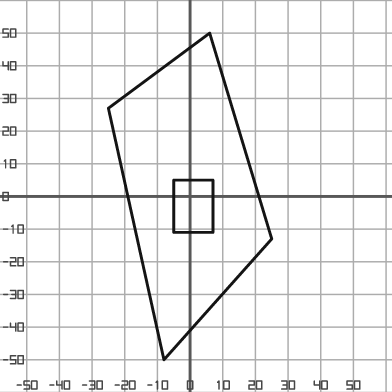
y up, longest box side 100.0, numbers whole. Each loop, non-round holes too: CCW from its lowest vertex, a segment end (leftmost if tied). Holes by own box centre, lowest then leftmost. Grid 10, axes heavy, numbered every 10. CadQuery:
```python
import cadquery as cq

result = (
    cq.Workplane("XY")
    .moveTo(-8.0, -50.0)
    .lineTo(25.0, -13.0)
    .lineTo(6.0, 50.0)
    .lineTo(-25.0, 27.0)
    .close()
    .moveTo(-5.0, -11.0)
    .lineTo(7.0, -11.0)
    .lineTo(7.0, 5.0)
    .lineTo(-5.0, 5.0)
    .close()
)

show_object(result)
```